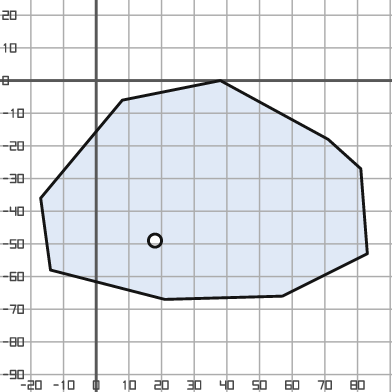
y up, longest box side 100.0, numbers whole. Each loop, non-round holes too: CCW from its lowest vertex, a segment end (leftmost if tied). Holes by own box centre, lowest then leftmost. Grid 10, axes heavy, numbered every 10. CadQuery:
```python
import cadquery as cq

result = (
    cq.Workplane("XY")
    .moveTo(21.0, -67.0)
    .lineTo(57.0, -66.0)
    .lineTo(83.0, -53.0)
    .lineTo(81.0, -27.0)
    .lineTo(71.0, -18.0)
    .lineTo(38.0, 0.0)
    .lineTo(8.0, -6.0)
    .lineTo(-17.0, -36.0)
    .lineTo(-14.0, -58.0)
    .close()
    .moveTo(18.0, -49.0)
    .circle(2.0)
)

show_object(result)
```